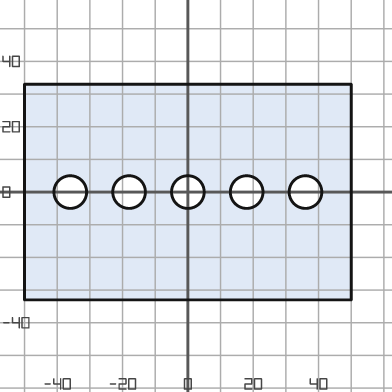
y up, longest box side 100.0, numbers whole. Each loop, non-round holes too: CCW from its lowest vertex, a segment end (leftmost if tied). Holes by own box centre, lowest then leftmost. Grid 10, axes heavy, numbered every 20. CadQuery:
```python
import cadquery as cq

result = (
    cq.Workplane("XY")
    .moveTo(-50.0, -33.0)
    .lineTo(50.0, -33.0)
    .lineTo(50.0, 33.0)
    .lineTo(-50.0, 33.0)
    .close()
    .moveTo(-36.0, 0.0)
    .circle(5.0)
    .moveTo(-18.0, 0.0)
    .circle(5.0)
    .moveTo(0.0, 0.0)
    .circle(5.0)
    .moveTo(18.0, 0.0)
    .circle(5.0)
    .moveTo(36.0, 0.0)
    .circle(5.0)
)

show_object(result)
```